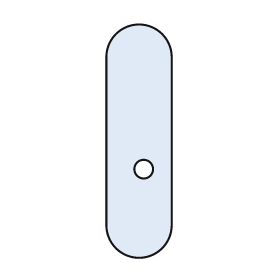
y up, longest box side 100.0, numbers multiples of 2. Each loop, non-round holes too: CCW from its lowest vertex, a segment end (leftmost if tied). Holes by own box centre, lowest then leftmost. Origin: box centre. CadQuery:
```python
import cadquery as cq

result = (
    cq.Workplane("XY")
    .moveTo(-14.0, -36.0)
    .threePointArc((0.0, -50.0), (14.0, -36.0))
    .lineTo(14.0, 36.0)
    .threePointArc((0.0, 50.0), (-14.0, 36.0))
    .close()
    .moveTo(2.0, -12.0)
    .circle(4.0)
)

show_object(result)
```